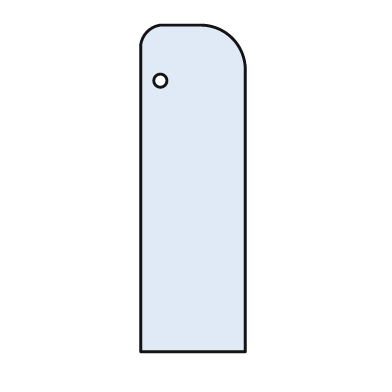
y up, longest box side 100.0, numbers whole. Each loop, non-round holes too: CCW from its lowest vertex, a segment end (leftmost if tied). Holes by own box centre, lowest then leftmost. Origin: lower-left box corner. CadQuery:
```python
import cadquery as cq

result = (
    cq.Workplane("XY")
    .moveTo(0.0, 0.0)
    .lineTo(32.0, 0.0)
    .lineTo(32.0, 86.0)
    .threePointArc((28.0, 96.0), (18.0, 100.0))
    .lineTo(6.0, 100.0)
    .threePointArc((2.0, 98.0), (0.0, 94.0))
    .close()
    .moveTo(6.0, 83.0)
    .circle(2.0)
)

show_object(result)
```